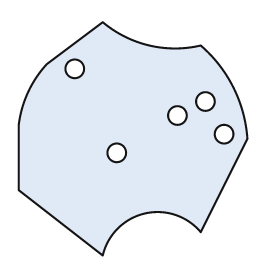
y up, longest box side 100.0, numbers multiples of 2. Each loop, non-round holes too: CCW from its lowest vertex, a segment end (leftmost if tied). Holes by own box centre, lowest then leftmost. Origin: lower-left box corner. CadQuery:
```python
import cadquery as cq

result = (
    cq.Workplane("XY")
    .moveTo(36.0, 0.0)
    .threePointArc((54.0, 18.0), (78.0, 10.0))
    .lineTo(98.0, 50.0)
    .threePointArc((92.0, 72.0), (78.0, 90.0))
    .threePointArc((56.0, 90.0), (36.0, 100.0))
    .lineTo(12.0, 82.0)
    .threePointArc((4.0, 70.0), (0.0, 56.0))
    .lineTo(0.0, 28.0)
    .close()
    .moveTo(42.0, 44.0)
    .circle(4.0)
    .moveTo(88.0, 52.0)
    .circle(4.0)
    .moveTo(68.0, 60.0)
    .circle(4.0)
    .moveTo(80.0, 66.0)
    .circle(4.0)
    .moveTo(24.0, 80.0)
    .circle(4.0)
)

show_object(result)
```